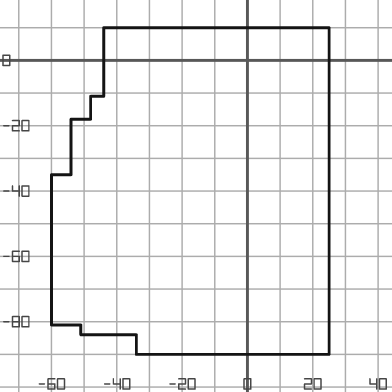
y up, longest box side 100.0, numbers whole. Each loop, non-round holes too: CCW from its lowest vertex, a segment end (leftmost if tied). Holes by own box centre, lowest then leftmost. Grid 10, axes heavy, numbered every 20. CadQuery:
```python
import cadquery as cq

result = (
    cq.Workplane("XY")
    .moveTo(-34.0, -90.0)
    .lineTo(25.0, -90.0)
    .lineTo(25.0, 10.0)
    .lineTo(-44.0, 10.0)
    .lineTo(-44.0, -11.0)
    .lineTo(-48.0, -11.0)
    .lineTo(-48.0, -18.0)
    .lineTo(-54.0, -18.0)
    .lineTo(-54.0, -35.0)
    .lineTo(-60.0, -35.0)
    .lineTo(-60.0, -81.0)
    .lineTo(-51.0, -81.0)
    .lineTo(-51.0, -84.0)
    .lineTo(-34.0, -84.0)
    .close()
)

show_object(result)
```